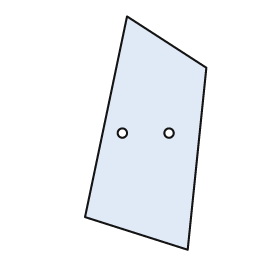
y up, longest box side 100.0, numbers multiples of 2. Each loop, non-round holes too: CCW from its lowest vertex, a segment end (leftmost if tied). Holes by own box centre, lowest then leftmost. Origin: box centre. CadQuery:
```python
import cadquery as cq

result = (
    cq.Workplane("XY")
    .moveTo(18.0, -50.0)
    .lineTo(26.0, 28.0)
    .lineTo(-8.0, 50.0)
    .lineTo(-26.0, -36.0)
    .close()
    .moveTo(-10.0, 0.0)
    .circle(2.0)
    .moveTo(10.0, 0.0)
    .circle(2.0)
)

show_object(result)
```